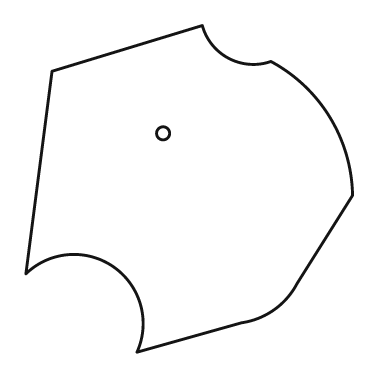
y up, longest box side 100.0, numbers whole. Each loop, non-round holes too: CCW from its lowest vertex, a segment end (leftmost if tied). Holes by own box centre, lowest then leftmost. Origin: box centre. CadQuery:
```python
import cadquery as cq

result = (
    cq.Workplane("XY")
    .moveTo(-16.0, -50.0)
    .lineTo(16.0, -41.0)
    .threePointArc((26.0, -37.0), (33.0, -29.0))
    .lineTo(50.0, -2.0)
    .threePointArc((43.0, 22.0), (25.0, 39.0))
    .threePointArc((12.0, 40.0), (4.0, 50.0))
    .lineTo(-42.0, 36.0)
    .lineTo(-50.0, -26.0)
    .threePointArc((-23.0, -24.0), (-16.0, -50.0))
    .close()
    .moveTo(-8.0, 17.0)
    .circle(2.0)
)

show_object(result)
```